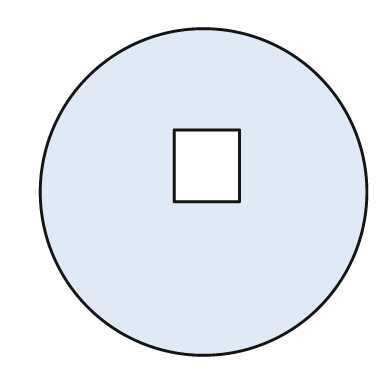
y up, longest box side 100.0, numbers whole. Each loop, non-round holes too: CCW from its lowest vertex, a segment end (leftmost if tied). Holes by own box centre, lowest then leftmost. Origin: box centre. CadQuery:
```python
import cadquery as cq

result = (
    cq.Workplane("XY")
    .moveTo(0.0, 0.0)
    .circle(50.0)
    .moveTo(-9.0, -3.0)
    .lineTo(11.0, -3.0)
    .lineTo(11.0, 19.0)
    .lineTo(-9.0, 19.0)
    .close()
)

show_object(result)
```